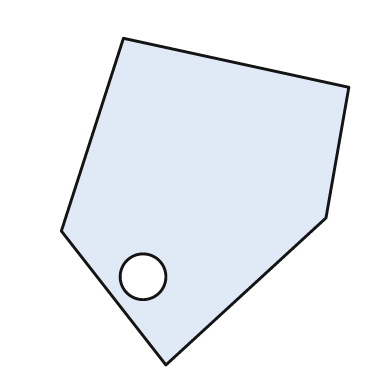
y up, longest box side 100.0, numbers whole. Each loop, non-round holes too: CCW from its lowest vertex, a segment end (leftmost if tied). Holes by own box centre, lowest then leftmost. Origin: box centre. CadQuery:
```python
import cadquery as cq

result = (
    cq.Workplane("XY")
    .moveTo(-12.0, -50.0)
    .lineTo(37.0, -5.0)
    .lineTo(44.0, 35.0)
    .lineTo(-25.0, 50.0)
    .lineTo(-44.0, -9.0)
    .close()
    .moveTo(-19.0, -23.0)
    .circle(7.0)
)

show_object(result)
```